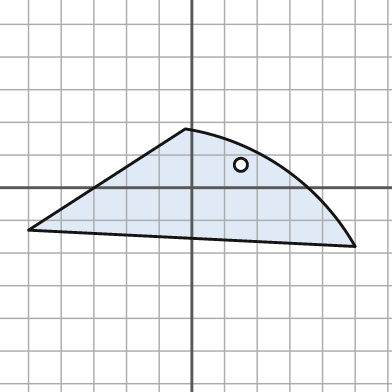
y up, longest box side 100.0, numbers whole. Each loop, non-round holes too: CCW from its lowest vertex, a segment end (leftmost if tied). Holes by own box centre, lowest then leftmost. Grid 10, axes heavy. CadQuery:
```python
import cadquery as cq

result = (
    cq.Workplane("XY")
    .moveTo(50.0, -18.0)
    .threePointArc((28.0, 6.0), (-2.0, 18.0))
    .lineTo(-50.0, -13.0)
    .close()
    .moveTo(15.0, 7.0)
    .circle(2.0)
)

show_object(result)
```